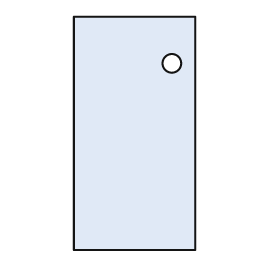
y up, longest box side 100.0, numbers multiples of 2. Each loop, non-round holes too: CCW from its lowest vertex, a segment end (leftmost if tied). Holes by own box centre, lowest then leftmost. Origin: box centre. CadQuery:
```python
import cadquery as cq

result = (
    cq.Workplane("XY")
    .moveTo(-26.0, -50.0)
    .lineTo(26.0, -50.0)
    .lineTo(26.0, 50.0)
    .lineTo(-26.0, 50.0)
    .close()
    .moveTo(16.0, 30.0)
    .circle(4.0)
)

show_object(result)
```